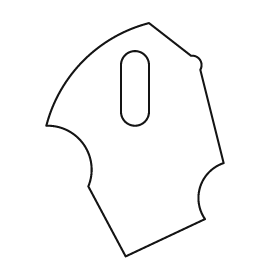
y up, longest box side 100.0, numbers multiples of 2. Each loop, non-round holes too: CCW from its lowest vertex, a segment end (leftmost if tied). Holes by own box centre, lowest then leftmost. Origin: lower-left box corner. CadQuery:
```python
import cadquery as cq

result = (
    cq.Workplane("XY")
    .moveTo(34.0, 0.0)
    .lineTo(68.0, 16.0)
    .threePointArc((66.0, 30.0), (76.0, 40.0))
    .lineTo(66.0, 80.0)
    .threePointArc((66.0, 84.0), (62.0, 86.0))
    .lineTo(44.0, 100.0)
    .threePointArc((16.0, 84.0), (0.0, 56.0))
    .threePointArc((16.0, 48.0), (18.0, 30.0))
    .close()
    .moveTo(32.0, 62.0)
    .threePointArc((38.0, 56.0), (44.0, 62.0))
    .lineTo(44.0, 82.0)
    .threePointArc((38.0, 88.0), (32.0, 82.0))
    .close()
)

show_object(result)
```